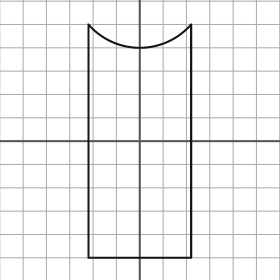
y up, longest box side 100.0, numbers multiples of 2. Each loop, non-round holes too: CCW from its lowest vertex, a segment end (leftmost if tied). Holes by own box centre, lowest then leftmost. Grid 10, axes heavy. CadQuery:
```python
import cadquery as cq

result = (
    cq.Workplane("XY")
    .moveTo(-22.0, -50.0)
    .lineTo(22.0, -50.0)
    .lineTo(22.0, 50.0)
    .threePointArc((0.0, 40.0), (-22.0, 50.0))
    .close()
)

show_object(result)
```